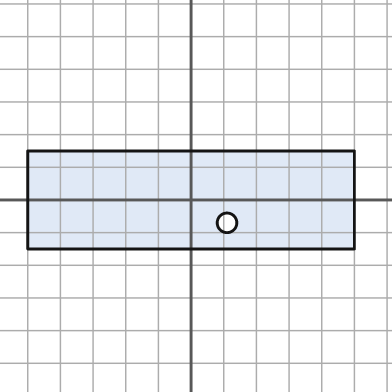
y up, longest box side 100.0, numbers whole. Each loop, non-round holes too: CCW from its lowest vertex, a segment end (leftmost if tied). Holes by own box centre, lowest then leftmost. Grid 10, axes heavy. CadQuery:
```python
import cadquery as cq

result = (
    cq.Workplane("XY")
    .moveTo(-50.0, -15.0)
    .lineTo(50.0, -15.0)
    .lineTo(50.0, 15.0)
    .lineTo(-50.0, 15.0)
    .close()
    .moveTo(11.0, -7.0)
    .circle(3.0)
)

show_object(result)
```